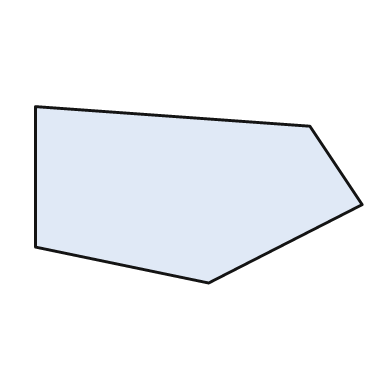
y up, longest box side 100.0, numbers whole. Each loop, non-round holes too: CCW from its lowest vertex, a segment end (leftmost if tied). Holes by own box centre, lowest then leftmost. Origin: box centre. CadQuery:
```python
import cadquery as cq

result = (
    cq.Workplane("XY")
    .moveTo(3.0, -27.0)
    .lineTo(50.0, -3.0)
    .lineTo(34.0, 21.0)
    .lineTo(-50.0, 27.0)
    .lineTo(-50.0, -16.0)
    .close()
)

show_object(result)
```